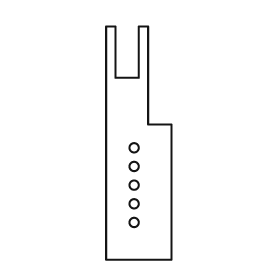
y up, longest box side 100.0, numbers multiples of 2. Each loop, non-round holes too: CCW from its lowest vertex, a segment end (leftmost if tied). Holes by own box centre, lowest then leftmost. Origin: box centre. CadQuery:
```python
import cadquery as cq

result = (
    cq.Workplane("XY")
    .moveTo(-14.0, -50.0)
    .lineTo(14.0, -50.0)
    .lineTo(14.0, 8.0)
    .lineTo(4.0, 8.0)
    .lineTo(4.0, 50.0)
    .lineTo(0.0, 50.0)
    .lineTo(0.0, 28.0)
    .lineTo(-10.0, 28.0)
    .lineTo(-10.0, 50.0)
    .lineTo(-14.0, 50.0)
    .close()
    .moveTo(-2.0, -34.0)
    .circle(2.0)
    .moveTo(-2.0, -26.0)
    .circle(2.0)
    .moveTo(-2.0, -18.0)
    .circle(2.0)
    .moveTo(-2.0, -10.0)
    .circle(2.0)
    .moveTo(-2.0, -2.0)
    .circle(2.0)
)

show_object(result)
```